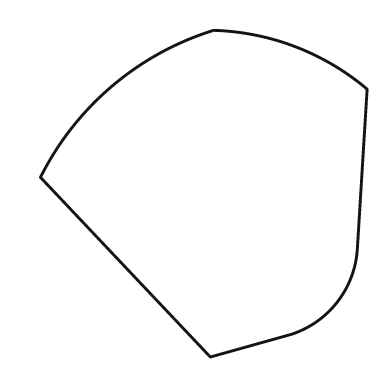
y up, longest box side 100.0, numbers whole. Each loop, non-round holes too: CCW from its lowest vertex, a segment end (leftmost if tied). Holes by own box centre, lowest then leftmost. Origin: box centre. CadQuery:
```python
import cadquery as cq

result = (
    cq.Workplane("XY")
    .moveTo(2.0, -50.0)
    .lineTo(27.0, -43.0)
    .threePointArc((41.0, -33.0), (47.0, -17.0))
    .lineTo(50.0, 32.0)
    .threePointArc((28.0, 45.0), (3.0, 50.0))
    .threePointArc((-28.0, 33.0), (-50.0, 5.0))
    .close()
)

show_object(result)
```